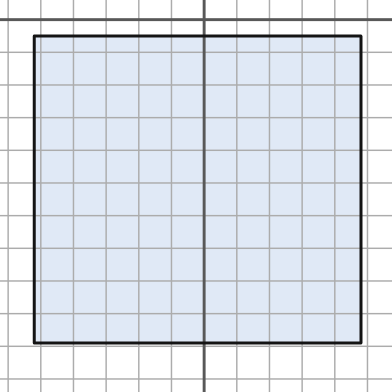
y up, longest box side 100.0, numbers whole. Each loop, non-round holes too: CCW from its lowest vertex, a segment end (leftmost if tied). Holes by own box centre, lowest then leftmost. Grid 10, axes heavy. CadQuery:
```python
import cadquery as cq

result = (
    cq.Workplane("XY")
    .moveTo(-52.0, -99.0)
    .lineTo(48.0, -99.0)
    .lineTo(48.0, -5.0)
    .lineTo(-52.0, -5.0)
    .close()
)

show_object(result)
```